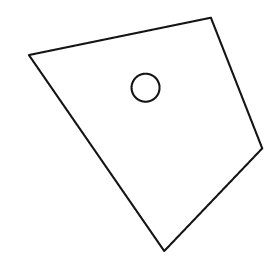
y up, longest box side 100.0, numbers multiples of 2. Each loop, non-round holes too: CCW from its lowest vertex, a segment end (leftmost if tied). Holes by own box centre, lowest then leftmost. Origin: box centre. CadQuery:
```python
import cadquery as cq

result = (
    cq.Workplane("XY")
    .moveTo(8.0, -50.0)
    .lineTo(50.0, -6.0)
    .lineTo(28.0, 50.0)
    .lineTo(-50.0, 34.0)
    .close()
    .moveTo(0.0, 20.0)
    .circle(6.0)
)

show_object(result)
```